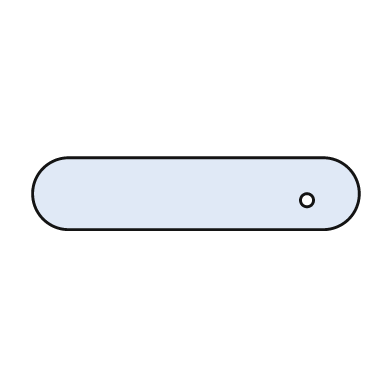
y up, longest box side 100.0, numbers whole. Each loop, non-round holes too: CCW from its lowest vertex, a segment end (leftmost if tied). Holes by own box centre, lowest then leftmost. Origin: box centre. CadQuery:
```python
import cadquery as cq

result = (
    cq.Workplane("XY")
    .moveTo(-39.0, -11.0)
    .lineTo(39.0, -11.0)
    .threePointArc((50.0, 0.0), (39.0, 11.0))
    .lineTo(-39.0, 11.0)
    .threePointArc((-50.0, 0.0), (-39.0, -11.0))
    .close()
    .moveTo(34.0, -2.0)
    .circle(2.0)
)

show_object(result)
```